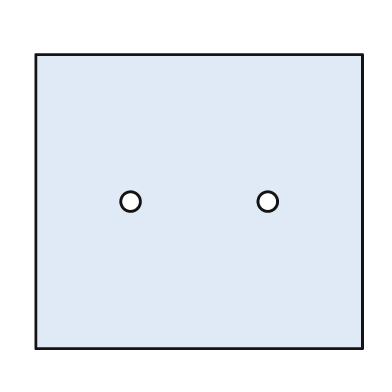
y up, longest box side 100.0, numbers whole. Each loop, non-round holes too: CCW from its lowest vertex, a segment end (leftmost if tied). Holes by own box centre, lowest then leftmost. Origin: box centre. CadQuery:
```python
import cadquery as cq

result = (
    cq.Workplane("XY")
    .moveTo(-50.0, -45.0)
    .lineTo(50.0, -45.0)
    .lineTo(50.0, 45.0)
    .lineTo(-50.0, 45.0)
    .close()
    .moveTo(-21.0, 0.0)
    .circle(3.0)
    .moveTo(21.0, 0.0)
    .circle(3.0)
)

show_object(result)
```